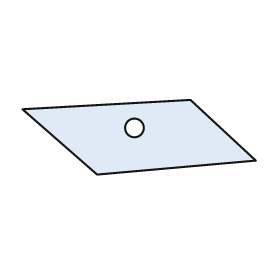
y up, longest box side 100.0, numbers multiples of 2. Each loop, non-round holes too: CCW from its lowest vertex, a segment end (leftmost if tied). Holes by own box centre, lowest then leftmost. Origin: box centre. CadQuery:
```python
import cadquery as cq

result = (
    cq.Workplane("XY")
    .moveTo(-18.0, -16.0)
    .lineTo(50.0, -10.0)
    .lineTo(22.0, 16.0)
    .lineTo(-50.0, 12.0)
    .close()
    .moveTo(-2.0, 4.0)
    .circle(4.0)
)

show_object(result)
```